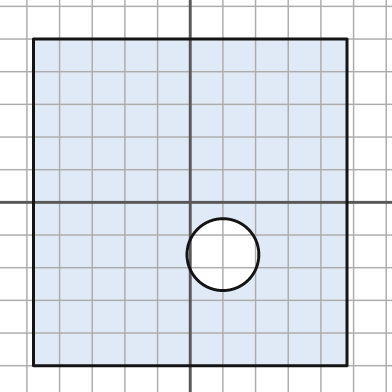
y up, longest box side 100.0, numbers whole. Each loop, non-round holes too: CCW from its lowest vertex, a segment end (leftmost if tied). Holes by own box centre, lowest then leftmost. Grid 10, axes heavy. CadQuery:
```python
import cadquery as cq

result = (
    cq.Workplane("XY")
    .moveTo(-48.0, -50.0)
    .lineTo(48.0, -50.0)
    .lineTo(48.0, 50.0)
    .lineTo(-48.0, 50.0)
    .close()
    .moveTo(10.0, -16.0)
    .circle(11.0)
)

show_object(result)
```